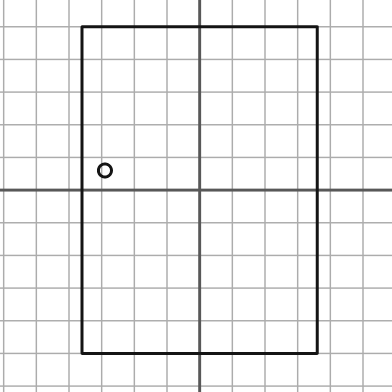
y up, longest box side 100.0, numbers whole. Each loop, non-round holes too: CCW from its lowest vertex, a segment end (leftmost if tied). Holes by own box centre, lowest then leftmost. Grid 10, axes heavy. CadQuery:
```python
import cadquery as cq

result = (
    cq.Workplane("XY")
    .moveTo(-36.0, -50.0)
    .lineTo(36.0, -50.0)
    .lineTo(36.0, 50.0)
    .lineTo(-36.0, 50.0)
    .close()
    .moveTo(-29.0, 6.0)
    .circle(2.0)
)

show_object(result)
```